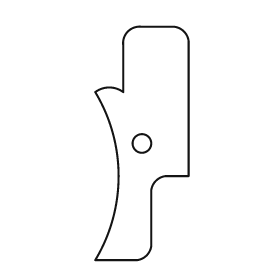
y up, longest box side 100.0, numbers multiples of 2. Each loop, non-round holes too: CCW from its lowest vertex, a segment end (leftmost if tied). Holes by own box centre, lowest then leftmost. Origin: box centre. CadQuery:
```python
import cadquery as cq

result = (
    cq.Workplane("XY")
    .moveTo(-20.0, -50.0)
    .lineTo(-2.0, -50.0)
    .threePointArc((2.0, -48.0), (4.0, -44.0))
    .lineTo(4.0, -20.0)
    .threePointArc((6.0, -16.0), (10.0, -14.0))
    .lineTo(20.0, -14.0)
    .lineTo(20.0, 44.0)
    .threePointArc((18.0, 48.0), (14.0, 50.0))
    .lineTo(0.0, 50.0)
    .threePointArc((-6.0, 48.0), (-8.0, 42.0))
    .lineTo(-8.0, 22.0)
    .threePointArc((-14.0, 24.0), (-20.0, 22.0))
    .threePointArc((-10.0, -14.0), (-20.0, -50.0))
    .close()
    .moveTo(0.0, 0.0)
    .circle(4.0)
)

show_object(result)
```